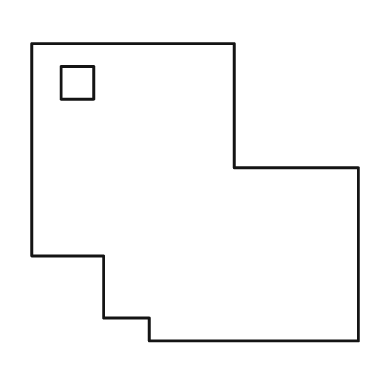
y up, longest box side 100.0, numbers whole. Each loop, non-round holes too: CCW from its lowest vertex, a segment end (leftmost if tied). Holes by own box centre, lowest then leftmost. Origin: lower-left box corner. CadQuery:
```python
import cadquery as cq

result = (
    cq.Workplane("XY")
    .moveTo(36.0, 0.0)
    .lineTo(100.0, 0.0)
    .lineTo(100.0, 53.0)
    .lineTo(62.0, 53.0)
    .lineTo(62.0, 91.0)
    .lineTo(0.0, 91.0)
    .lineTo(0.0, 26.0)
    .lineTo(22.0, 26.0)
    .lineTo(22.0, 7.0)
    .lineTo(36.0, 7.0)
    .close()
    .moveTo(9.0, 74.0)
    .lineTo(19.0, 74.0)
    .lineTo(19.0, 84.0)
    .lineTo(9.0, 84.0)
    .close()
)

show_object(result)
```